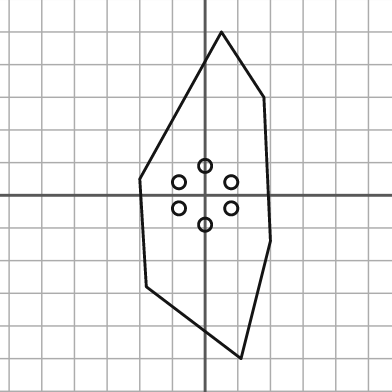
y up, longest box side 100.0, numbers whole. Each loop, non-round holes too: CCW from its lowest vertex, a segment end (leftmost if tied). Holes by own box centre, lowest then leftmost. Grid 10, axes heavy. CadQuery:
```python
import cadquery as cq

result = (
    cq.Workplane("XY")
    .moveTo(11.0, -50.0)
    .lineTo(20.0, -14.0)
    .lineTo(18.0, 30.0)
    .lineTo(5.0, 50.0)
    .lineTo(-20.0, 5.0)
    .lineTo(-18.0, -28.0)
    .close()
    .moveTo(0.0, -9.0)
    .circle(2.0)
    .moveTo(-8.0, -4.0)
    .circle(2.0)
    .moveTo(8.0, -4.0)
    .circle(2.0)
    .moveTo(-8.0, 4.0)
    .circle(2.0)
    .moveTo(8.0, 4.0)
    .circle(2.0)
    .moveTo(0.0, 9.0)
    .circle(2.0)
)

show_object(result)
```